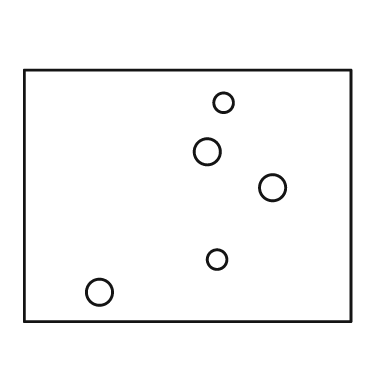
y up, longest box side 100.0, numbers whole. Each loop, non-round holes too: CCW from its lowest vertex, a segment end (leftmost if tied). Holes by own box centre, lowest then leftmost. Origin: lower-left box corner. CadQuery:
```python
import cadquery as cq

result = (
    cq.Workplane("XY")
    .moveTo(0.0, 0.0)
    .lineTo(100.0, 0.0)
    .lineTo(100.0, 77.0)
    .lineTo(0.0, 77.0)
    .close()
    .moveTo(23.0, 9.0)
    .circle(4.0)
    .moveTo(59.0, 19.0)
    .circle(3.0)
    .moveTo(76.0, 41.0)
    .circle(4.0)
    .moveTo(56.0, 52.0)
    .circle(4.0)
    .moveTo(61.0, 67.0)
    .circle(3.0)
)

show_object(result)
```